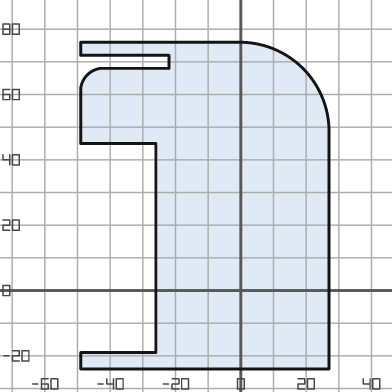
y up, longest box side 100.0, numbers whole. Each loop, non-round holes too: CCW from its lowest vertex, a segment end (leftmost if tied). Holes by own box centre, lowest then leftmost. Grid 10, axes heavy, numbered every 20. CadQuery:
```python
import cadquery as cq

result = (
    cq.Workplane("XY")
    .moveTo(-49.0, -24.0)
    .lineTo(27.0, -24.0)
    .lineTo(27.0, 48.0)
    .threePointArc((19.0, 68.0), (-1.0, 76.0))
    .lineTo(-49.0, 76.0)
    .lineTo(-49.0, 72.0)
    .lineTo(-22.0, 72.0)
    .lineTo(-22.0, 68.0)
    .lineTo(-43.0, 68.0)
    .threePointArc((-47.0, 66.0), (-49.0, 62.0))
    .lineTo(-49.0, 45.0)
    .lineTo(-26.0, 45.0)
    .lineTo(-26.0, -19.0)
    .lineTo(-49.0, -19.0)
    .close()
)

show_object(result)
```